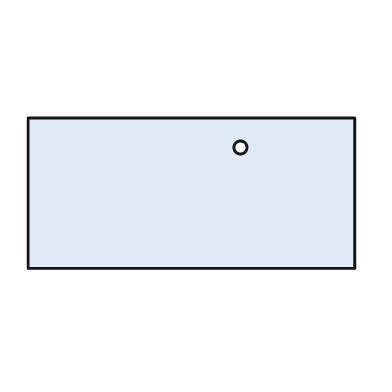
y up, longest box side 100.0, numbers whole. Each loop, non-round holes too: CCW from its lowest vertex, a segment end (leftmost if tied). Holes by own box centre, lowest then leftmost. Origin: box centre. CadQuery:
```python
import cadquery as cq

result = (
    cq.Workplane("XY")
    .moveTo(-50.0, -23.0)
    .lineTo(50.0, -23.0)
    .lineTo(50.0, 23.0)
    .lineTo(-50.0, 23.0)
    .close()
    .moveTo(15.0, 14.0)
    .circle(2.0)
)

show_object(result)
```